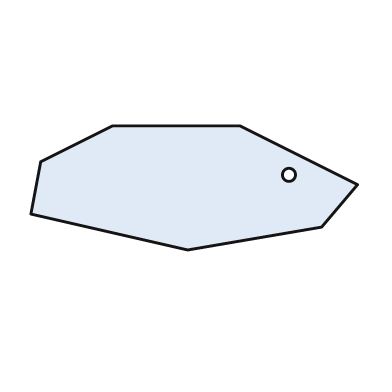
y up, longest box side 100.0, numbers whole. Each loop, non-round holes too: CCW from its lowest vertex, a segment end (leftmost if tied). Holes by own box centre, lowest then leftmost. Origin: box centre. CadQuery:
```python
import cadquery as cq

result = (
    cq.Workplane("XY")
    .moveTo(-2.0, -19.0)
    .lineTo(39.0, -12.0)
    .lineTo(50.0, 1.0)
    .lineTo(14.0, 19.0)
    .lineTo(-25.0, 19.0)
    .lineTo(-47.0, 8.0)
    .lineTo(-50.0, -8.0)
    .close()
    .moveTo(29.0, 4.0)
    .circle(2.0)
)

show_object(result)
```